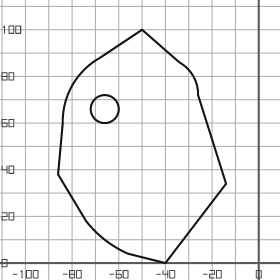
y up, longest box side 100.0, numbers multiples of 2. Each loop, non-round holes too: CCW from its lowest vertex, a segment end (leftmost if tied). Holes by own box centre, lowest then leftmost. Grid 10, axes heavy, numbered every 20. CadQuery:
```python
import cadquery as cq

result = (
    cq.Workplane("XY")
    .moveTo(-40.0, 0.0)
    .lineTo(-14.0, 34.0)
    .lineTo(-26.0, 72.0)
    .threePointArc((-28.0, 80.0), (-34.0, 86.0))
    .lineTo(-50.0, 100.0)
    .lineTo(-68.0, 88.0)
    .threePointArc((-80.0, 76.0), (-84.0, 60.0))
    .lineTo(-86.0, 38.0)
    .lineTo(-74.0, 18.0)
    .threePointArc((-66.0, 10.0), (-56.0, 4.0))
    .close()
    .moveTo(-66.0, 66.0)
    .circle(6.0)
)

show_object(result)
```